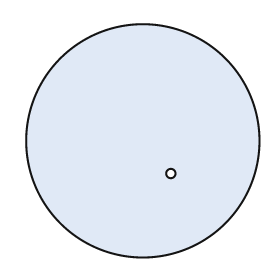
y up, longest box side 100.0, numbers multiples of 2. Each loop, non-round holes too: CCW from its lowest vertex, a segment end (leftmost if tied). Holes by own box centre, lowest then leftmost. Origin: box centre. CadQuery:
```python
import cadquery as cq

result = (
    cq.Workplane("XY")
    .moveTo(0.0, 0.0)
    .circle(50.0)
    .moveTo(12.0, -14.0)
    .circle(2.0)
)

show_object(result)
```